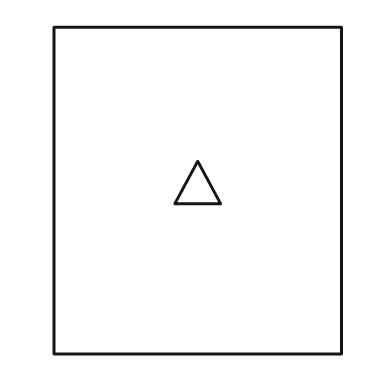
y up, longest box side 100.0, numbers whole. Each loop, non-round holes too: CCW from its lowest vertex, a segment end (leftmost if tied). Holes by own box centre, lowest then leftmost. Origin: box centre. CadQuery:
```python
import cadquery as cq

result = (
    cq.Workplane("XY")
    .moveTo(-44.0, -50.0)
    .lineTo(44.0, -50.0)
    .lineTo(44.0, 50.0)
    .lineTo(-44.0, 50.0)
    .close()
    .moveTo(-7.0, -4.0)
    .lineTo(7.0, -4.0)
    .lineTo(0.0, 9.0)
    .close()
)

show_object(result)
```